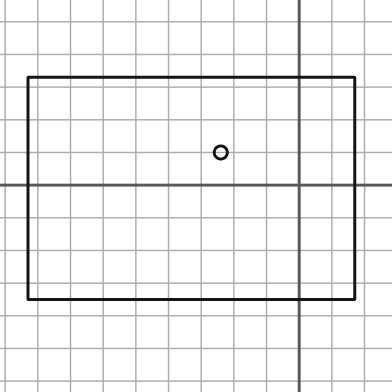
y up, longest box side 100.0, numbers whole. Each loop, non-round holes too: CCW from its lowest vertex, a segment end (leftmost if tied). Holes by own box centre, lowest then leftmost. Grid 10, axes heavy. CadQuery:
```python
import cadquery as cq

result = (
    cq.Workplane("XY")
    .moveTo(-83.0, -35.0)
    .lineTo(17.0, -35.0)
    .lineTo(17.0, 33.0)
    .lineTo(-83.0, 33.0)
    .close()
    .moveTo(-24.0, 10.0)
    .circle(2.0)
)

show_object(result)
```